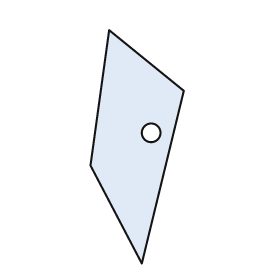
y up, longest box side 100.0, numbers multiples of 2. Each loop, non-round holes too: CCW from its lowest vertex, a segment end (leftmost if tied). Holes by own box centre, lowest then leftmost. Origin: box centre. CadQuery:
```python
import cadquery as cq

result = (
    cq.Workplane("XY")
    .moveTo(2.0, -50.0)
    .lineTo(20.0, 24.0)
    .lineTo(-12.0, 50.0)
    .lineTo(-20.0, -8.0)
    .close()
    .moveTo(6.0, 6.0)
    .circle(4.0)
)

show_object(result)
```